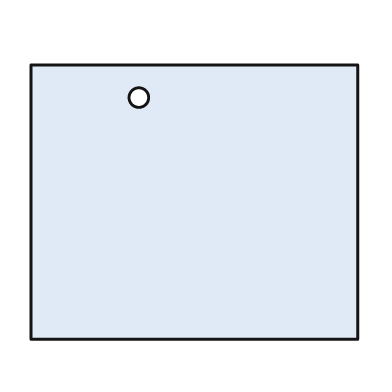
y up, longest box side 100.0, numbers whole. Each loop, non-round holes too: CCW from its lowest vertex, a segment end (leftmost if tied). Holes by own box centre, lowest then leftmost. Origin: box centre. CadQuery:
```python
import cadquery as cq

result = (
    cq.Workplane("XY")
    .moveTo(-50.0, -42.0)
    .lineTo(50.0, -42.0)
    .lineTo(50.0, 42.0)
    .lineTo(-50.0, 42.0)
    .close()
    .moveTo(-17.0, 32.0)
    .circle(3.0)
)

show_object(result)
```